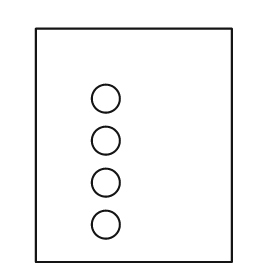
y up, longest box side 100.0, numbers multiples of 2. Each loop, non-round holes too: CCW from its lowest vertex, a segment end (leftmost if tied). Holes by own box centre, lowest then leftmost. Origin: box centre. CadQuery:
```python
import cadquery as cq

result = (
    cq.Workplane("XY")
    .moveTo(-42.0, -50.0)
    .lineTo(42.0, -50.0)
    .lineTo(42.0, 50.0)
    .lineTo(-42.0, 50.0)
    .close()
    .moveTo(-12.0, -34.0)
    .circle(6.0)
    .moveTo(-12.0, -16.0)
    .circle(6.0)
    .moveTo(-12.0, 2.0)
    .circle(6.0)
    .moveTo(-12.0, 20.0)
    .circle(6.0)
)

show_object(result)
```